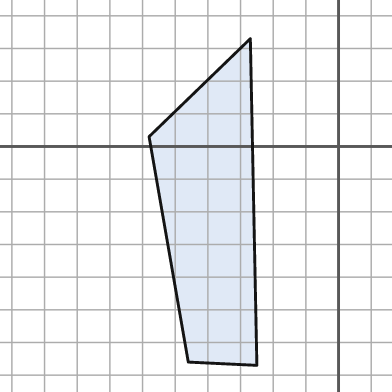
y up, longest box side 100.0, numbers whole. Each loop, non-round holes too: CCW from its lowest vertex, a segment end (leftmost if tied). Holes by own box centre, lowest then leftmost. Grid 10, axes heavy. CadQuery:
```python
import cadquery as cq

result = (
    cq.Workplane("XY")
    .moveTo(-25.0, -67.0)
    .lineTo(-27.0, 33.0)
    .lineTo(-58.0, 3.0)
    .lineTo(-46.0, -66.0)
    .close()
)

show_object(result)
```